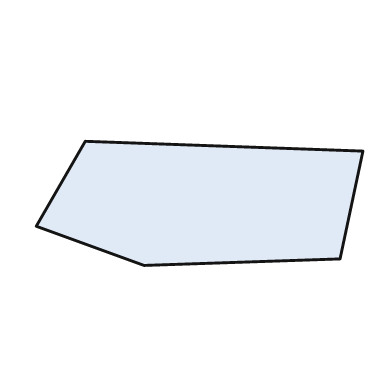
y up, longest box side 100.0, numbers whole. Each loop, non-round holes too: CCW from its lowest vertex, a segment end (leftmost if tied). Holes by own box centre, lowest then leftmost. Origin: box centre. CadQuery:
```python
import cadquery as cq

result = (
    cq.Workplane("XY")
    .moveTo(-17.0, -19.0)
    .lineTo(43.0, -17.0)
    .lineTo(50.0, 16.0)
    .lineTo(-35.0, 19.0)
    .lineTo(-50.0, -7.0)
    .close()
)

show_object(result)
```